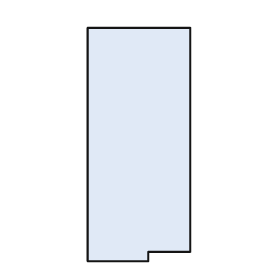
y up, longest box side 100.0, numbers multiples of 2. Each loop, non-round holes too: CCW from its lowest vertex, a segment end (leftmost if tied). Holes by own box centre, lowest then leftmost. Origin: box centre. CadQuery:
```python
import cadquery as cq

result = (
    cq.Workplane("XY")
    .moveTo(-22.0, -50.0)
    .lineTo(4.0, -50.0)
    .lineTo(4.0, -46.0)
    .lineTo(22.0, -46.0)
    .lineTo(22.0, 50.0)
    .lineTo(-22.0, 50.0)
    .close()
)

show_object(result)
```